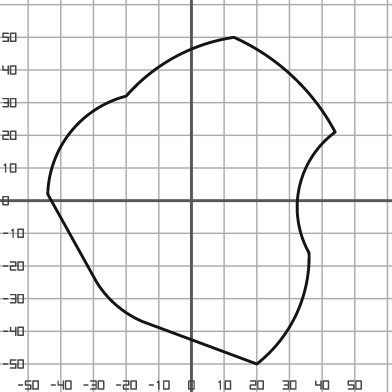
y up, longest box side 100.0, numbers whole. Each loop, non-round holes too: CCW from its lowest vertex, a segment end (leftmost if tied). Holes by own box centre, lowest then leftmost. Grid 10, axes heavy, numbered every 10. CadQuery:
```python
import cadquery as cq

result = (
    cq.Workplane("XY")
    .moveTo(20.0, -50.0)
    .threePointArc((32.0, -35.0), (36.0, -16.0))
    .threePointArc((33.0, 4.0), (44.0, 21.0))
    .threePointArc((31.0, 38.0), (13.0, 50.0))
    .threePointArc((-5.0, 44.0), (-20.0, 32.0))
    .threePointArc((-37.0, 21.0), (-44.0, 2.0))
    .lineTo(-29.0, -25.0)
    .threePointArc((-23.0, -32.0), (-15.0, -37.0))
    .close()
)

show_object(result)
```